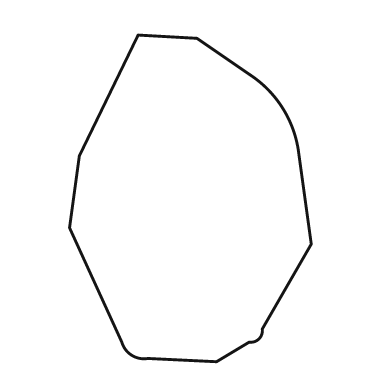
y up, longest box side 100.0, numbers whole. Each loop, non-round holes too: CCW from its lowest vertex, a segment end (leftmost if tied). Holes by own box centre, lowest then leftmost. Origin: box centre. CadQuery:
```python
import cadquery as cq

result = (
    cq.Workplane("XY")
    .moveTo(8.0, -50.0)
    .lineTo(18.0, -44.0)
    .threePointArc((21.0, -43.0), (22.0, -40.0))
    .lineTo(37.0, -14.0)
    .lineTo(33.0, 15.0)
    .threePointArc((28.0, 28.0), (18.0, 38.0))
    .lineTo(2.0, 49.0)
    .lineTo(-16.0, 50.0)
    .lineTo(-34.0, 13.0)
    .lineTo(-37.0, -9.0)
    .lineTo(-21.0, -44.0)
    .threePointArc((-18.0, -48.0), (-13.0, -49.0))
    .close()
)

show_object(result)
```